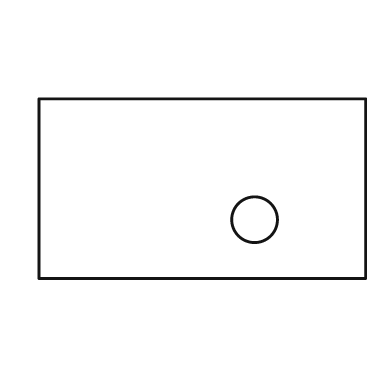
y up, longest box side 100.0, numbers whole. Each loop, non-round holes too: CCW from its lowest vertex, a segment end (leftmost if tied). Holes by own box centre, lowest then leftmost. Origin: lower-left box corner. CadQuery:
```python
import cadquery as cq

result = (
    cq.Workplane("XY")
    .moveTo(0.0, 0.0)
    .lineTo(100.0, 0.0)
    .lineTo(100.0, 55.0)
    .lineTo(0.0, 55.0)
    .close()
    .moveTo(66.0, 18.0)
    .circle(7.0)
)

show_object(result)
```